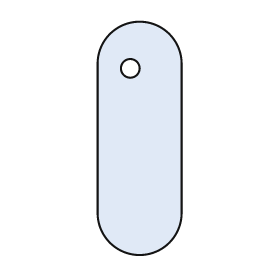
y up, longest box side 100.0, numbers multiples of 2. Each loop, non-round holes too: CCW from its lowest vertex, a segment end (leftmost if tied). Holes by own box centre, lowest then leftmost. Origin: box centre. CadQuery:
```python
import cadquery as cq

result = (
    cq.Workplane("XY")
    .moveTo(-18.0, -32.0)
    .threePointArc((0.0, -50.0), (18.0, -32.0))
    .lineTo(18.0, 32.0)
    .threePointArc((0.0, 50.0), (-18.0, 32.0))
    .close()
    .moveTo(-4.0, 30.0)
    .circle(4.0)
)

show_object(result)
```